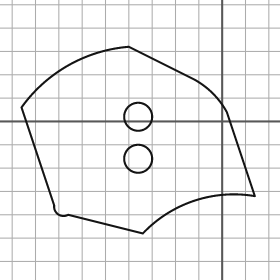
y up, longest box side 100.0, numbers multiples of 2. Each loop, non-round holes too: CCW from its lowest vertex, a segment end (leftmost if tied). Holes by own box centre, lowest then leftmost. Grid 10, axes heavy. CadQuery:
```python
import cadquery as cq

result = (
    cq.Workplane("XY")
    .moveTo(-34.0, -48.0)
    .threePointArc((-12.0, -34.0), (14.0, -32.0))
    .lineTo(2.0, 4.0)
    .threePointArc((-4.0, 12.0), (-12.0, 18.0))
    .lineTo(-40.0, 32.0)
    .threePointArc((-66.0, 24.0), (-86.0, 6.0))
    .lineTo(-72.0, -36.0)
    .threePointArc((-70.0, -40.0), (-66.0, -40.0))
    .close()
    .moveTo(-36.0, -16.0)
    .circle(6.0)
    .moveTo(-36.0, 2.0)
    .circle(6.0)
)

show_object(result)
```